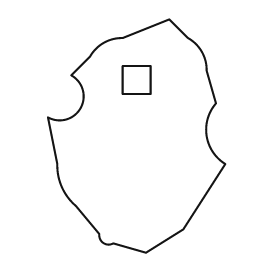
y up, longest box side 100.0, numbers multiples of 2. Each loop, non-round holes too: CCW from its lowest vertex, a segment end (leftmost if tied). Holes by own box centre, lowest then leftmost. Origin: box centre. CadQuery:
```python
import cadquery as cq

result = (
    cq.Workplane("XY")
    .moveTo(4.0, -50.0)
    .lineTo(20.0, -40.0)
    .lineTo(38.0, -12.0)
    .threePointArc((30.0, 0.0), (34.0, 14.0))
    .lineTo(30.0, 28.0)
    .threePointArc((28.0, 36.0), (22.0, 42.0))
    .lineTo(14.0, 50.0)
    .lineTo(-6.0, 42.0)
    .threePointArc((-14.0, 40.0), (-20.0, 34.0))
    .lineTo(-28.0, 26.0)
    .threePointArc((-24.0, 12.0), (-38.0, 8.0))
    .lineTo(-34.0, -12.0)
    .threePointArc((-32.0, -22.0), (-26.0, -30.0))
    .lineTo(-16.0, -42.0)
    .threePointArc((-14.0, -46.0), (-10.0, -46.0))
    .close()
    .moveTo(-6.0, 18.0)
    .lineTo(6.0, 18.0)
    .lineTo(6.0, 30.0)
    .lineTo(-6.0, 30.0)
    .close()
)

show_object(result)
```